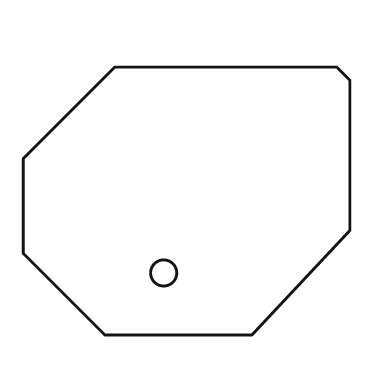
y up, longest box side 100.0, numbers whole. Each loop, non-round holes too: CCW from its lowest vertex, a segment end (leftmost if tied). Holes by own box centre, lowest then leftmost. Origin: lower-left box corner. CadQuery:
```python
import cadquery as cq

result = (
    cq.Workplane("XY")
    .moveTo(25.0, 0.0)
    .lineTo(70.0, 0.0)
    .lineTo(100.0, 32.0)
    .lineTo(100.0, 78.0)
    .lineTo(96.0, 82.0)
    .lineTo(28.0, 82.0)
    .lineTo(0.0, 54.0)
    .lineTo(0.0, 25.0)
    .close()
    .moveTo(43.0, 19.0)
    .circle(4.0)
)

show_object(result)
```